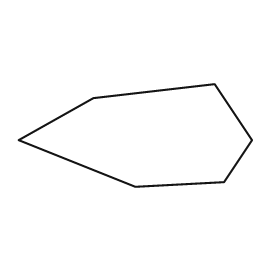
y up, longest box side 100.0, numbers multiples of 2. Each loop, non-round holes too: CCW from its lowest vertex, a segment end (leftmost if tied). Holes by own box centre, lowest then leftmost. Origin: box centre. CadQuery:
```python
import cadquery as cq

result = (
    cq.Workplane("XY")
    .moveTo(0.0, -22.0)
    .lineTo(38.0, -20.0)
    .lineTo(50.0, -2.0)
    .lineTo(34.0, 22.0)
    .lineTo(-18.0, 16.0)
    .lineTo(-50.0, -2.0)
    .close()
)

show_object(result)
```